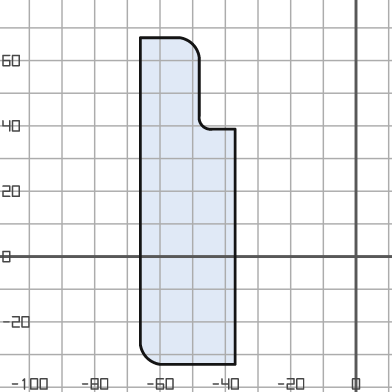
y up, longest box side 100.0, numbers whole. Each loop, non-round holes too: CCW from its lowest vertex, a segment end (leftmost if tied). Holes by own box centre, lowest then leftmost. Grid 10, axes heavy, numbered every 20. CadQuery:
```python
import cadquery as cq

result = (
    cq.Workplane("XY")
    .moveTo(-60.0, -33.0)
    .lineTo(-37.0, -33.0)
    .lineTo(-37.0, 39.0)
    .lineTo(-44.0, 39.0)
    .threePointArc((-47.0, 40.0), (-48.0, 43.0))
    .lineTo(-48.0, 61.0)
    .threePointArc((-50.0, 65.0), (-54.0, 67.0))
    .lineTo(-66.0, 67.0)
    .lineTo(-66.0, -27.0)
    .threePointArc((-64.0, -31.0), (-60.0, -33.0))
    .close()
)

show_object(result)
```